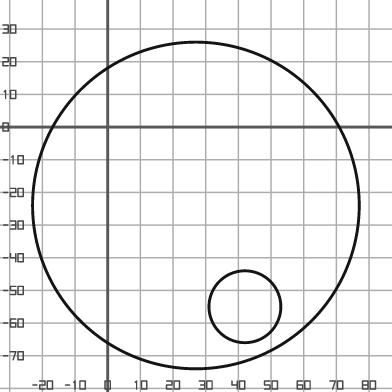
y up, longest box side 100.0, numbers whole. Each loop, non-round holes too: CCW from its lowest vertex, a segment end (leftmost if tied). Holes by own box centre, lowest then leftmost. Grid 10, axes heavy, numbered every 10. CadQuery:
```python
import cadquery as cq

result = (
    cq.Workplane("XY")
    .moveTo(27.0, -24.0)
    .circle(50.0)
    .moveTo(42.0, -55.0)
    .circle(11.0)
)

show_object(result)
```